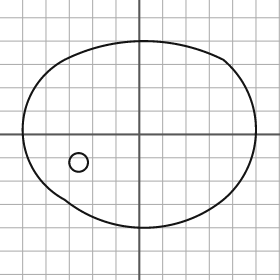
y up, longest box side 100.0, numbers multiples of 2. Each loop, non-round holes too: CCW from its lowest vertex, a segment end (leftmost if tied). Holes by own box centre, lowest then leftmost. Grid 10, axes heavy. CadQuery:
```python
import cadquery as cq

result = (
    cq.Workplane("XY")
    .moveTo(-32.0, -28.0)
    .threePointArc((2.0, -40.0), (36.0, -28.0))
    .threePointArc((50.0, 2.0), (36.0, 32.0))
    .threePointArc((2.0, 40.0), (-32.0, 32.0))
    .threePointArc((-50.0, 2.0), (-32.0, -28.0))
    .close()
    .moveTo(-26.0, -12.0)
    .circle(4.0)
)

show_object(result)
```